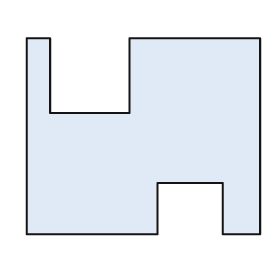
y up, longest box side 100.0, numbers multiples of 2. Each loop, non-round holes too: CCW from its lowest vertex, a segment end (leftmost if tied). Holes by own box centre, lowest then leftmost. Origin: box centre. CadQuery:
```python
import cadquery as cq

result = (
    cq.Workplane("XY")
    .moveTo(-50.0, -42.0)
    .lineTo(6.0, -42.0)
    .lineTo(6.0, -20.0)
    .lineTo(34.0, -20.0)
    .lineTo(34.0, -42.0)
    .lineTo(50.0, -42.0)
    .lineTo(50.0, 42.0)
    .lineTo(-6.0, 42.0)
    .lineTo(-6.0, 10.0)
    .lineTo(-40.0, 10.0)
    .lineTo(-40.0, 42.0)
    .lineTo(-50.0, 42.0)
    .close()
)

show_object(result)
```